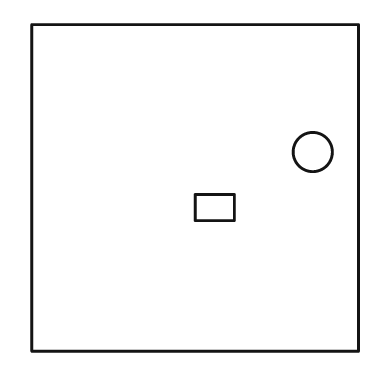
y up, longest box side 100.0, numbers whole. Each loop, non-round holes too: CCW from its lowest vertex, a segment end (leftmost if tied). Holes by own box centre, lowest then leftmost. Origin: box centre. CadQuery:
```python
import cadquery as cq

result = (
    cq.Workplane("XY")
    .moveTo(-50.0, -50.0)
    .lineTo(50.0, -50.0)
    .lineTo(50.0, 50.0)
    .lineTo(-50.0, 50.0)
    .close()
    .moveTo(0.0, -10.0)
    .lineTo(12.0, -10.0)
    .lineTo(12.0, -2.0)
    .lineTo(0.0, -2.0)
    .close()
    .moveTo(36.0, 11.0)
    .circle(6.0)
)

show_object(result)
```